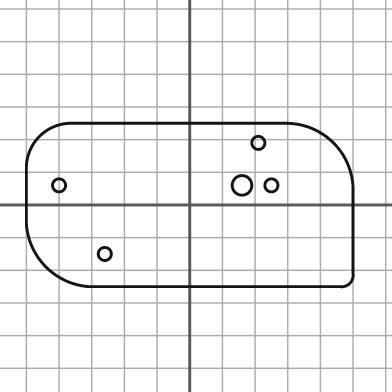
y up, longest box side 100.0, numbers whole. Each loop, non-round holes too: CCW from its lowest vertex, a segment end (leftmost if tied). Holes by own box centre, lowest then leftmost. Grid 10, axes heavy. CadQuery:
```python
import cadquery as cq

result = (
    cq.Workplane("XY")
    .moveTo(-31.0, -25.0)
    .lineTo(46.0, -25.0)
    .threePointArc((49.0, -24.0), (50.0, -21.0))
    .lineTo(50.0, 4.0)
    .threePointArc((44.0, 19.0), (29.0, 25.0))
    .lineTo(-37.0, 25.0)
    .threePointArc((-46.0, 21.0), (-50.0, 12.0))
    .lineTo(-50.0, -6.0)
    .threePointArc((-44.0, -19.0), (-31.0, -25.0))
    .close()
    .moveTo(-26.0, -15.0)
    .circle(2.0)
    .moveTo(-40.0, 6.0)
    .circle(2.0)
    .moveTo(16.0, 6.0)
    .circle(3.0)
    .moveTo(25.0, 6.0)
    .circle(2.0)
    .moveTo(21.0, 19.0)
    .circle(2.0)
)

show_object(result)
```